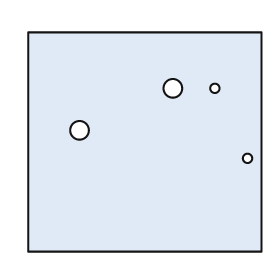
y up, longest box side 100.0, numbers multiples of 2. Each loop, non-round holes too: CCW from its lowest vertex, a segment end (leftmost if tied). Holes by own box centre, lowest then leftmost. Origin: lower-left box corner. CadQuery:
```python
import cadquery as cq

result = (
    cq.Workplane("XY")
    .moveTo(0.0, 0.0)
    .lineTo(100.0, 0.0)
    .lineTo(100.0, 94.0)
    .lineTo(0.0, 94.0)
    .close()
    .moveTo(94.0, 40.0)
    .circle(2.0)
    .moveTo(22.0, 52.0)
    .circle(4.0)
    .moveTo(62.0, 70.0)
    .circle(4.0)
    .moveTo(80.0, 70.0)
    .circle(2.0)
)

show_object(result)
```